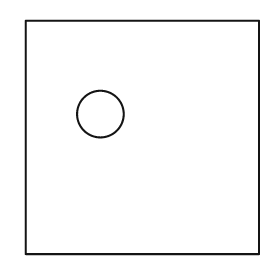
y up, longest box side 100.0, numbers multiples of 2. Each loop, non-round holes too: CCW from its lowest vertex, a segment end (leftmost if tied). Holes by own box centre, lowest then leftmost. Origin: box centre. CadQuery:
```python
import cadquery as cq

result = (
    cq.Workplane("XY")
    .moveTo(-50.0, -50.0)
    .lineTo(50.0, -50.0)
    .lineTo(50.0, 50.0)
    .lineTo(-50.0, 50.0)
    .close()
    .moveTo(-18.0, 10.0)
    .circle(10.0)
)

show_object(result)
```